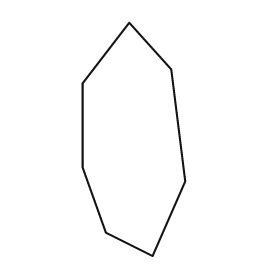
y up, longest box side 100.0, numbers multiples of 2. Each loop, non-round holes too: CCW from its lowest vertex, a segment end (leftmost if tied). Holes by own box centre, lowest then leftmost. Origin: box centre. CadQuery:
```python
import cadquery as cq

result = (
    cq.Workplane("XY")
    .moveTo(8.0, -50.0)
    .lineTo(22.0, -18.0)
    .lineTo(16.0, 30.0)
    .lineTo(-2.0, 50.0)
    .lineTo(-22.0, 24.0)
    .lineTo(-22.0, -12.0)
    .lineTo(-12.0, -40.0)
    .close()
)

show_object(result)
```